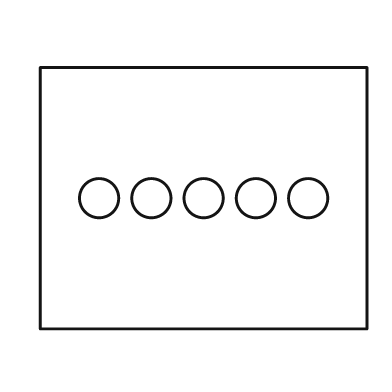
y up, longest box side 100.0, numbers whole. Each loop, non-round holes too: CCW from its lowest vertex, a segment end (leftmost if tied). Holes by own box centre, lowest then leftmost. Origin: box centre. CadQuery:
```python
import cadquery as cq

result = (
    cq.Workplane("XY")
    .moveTo(-50.0, -40.0)
    .lineTo(50.0, -40.0)
    .lineTo(50.0, 40.0)
    .lineTo(-50.0, 40.0)
    .close()
    .moveTo(-32.0, 0.0)
    .circle(6.0)
    .moveTo(-16.0, 0.0)
    .circle(6.0)
    .moveTo(0.0, 0.0)
    .circle(6.0)
    .moveTo(16.0, 0.0)
    .circle(6.0)
    .moveTo(32.0, 0.0)
    .circle(6.0)
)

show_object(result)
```